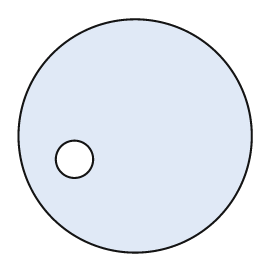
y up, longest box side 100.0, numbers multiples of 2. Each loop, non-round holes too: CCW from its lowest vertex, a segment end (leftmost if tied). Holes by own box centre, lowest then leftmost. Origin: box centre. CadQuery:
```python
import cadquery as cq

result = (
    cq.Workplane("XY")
    .moveTo(0.0, 0.0)
    .circle(50.0)
    .moveTo(-26.0, -10.0)
    .circle(8.0)
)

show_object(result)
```